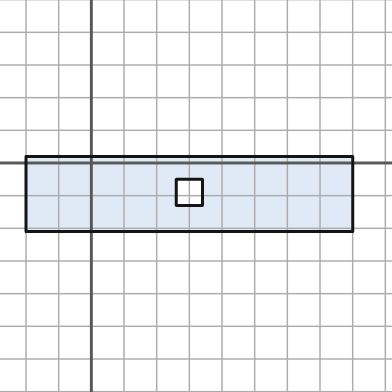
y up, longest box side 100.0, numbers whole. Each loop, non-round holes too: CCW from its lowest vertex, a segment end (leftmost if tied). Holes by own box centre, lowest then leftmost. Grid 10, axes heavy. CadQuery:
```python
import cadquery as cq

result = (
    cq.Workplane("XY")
    .moveTo(-20.0, -21.0)
    .lineTo(80.0, -21.0)
    .lineTo(80.0, 2.0)
    .lineTo(-20.0, 2.0)
    .close()
    .moveTo(26.0, -13.0)
    .lineTo(34.0, -13.0)
    .lineTo(34.0, -5.0)
    .lineTo(26.0, -5.0)
    .close()
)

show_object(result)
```